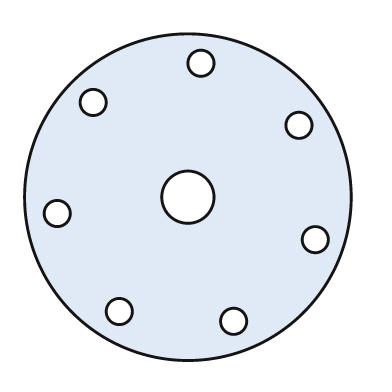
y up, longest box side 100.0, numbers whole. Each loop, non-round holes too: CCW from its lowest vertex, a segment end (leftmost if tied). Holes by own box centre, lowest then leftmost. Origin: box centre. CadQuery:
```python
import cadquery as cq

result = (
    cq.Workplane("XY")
    .moveTo(0.0, 0.0)
    .circle(50.0)
    .moveTo(14.0, -38.0)
    .circle(4.0)
    .moveTo(-21.0, -35.0)
    .circle(4.0)
    .moveTo(39.0, -13.0)
    .circle(4.0)
    .moveTo(-40.0, -5.0)
    .circle(4.0)
    .moveTo(0.0, 0.0)
    .circle(8.0)
    .moveTo(34.0, 22.0)
    .circle(4.0)
    .moveTo(-29.0, 29.0)
    .circle(4.0)
    .moveTo(4.0, 41.0)
    .circle(4.0)
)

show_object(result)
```